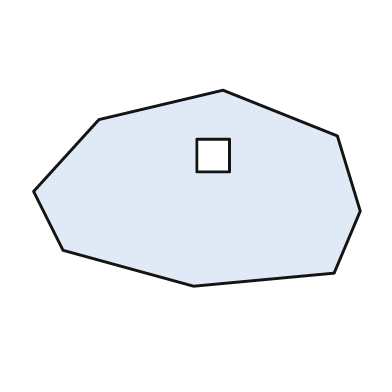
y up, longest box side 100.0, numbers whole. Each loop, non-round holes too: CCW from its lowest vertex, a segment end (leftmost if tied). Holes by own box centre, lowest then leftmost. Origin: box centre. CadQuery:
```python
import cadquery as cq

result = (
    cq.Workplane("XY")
    .moveTo(-1.0, -30.0)
    .lineTo(42.0, -26.0)
    .lineTo(50.0, -7.0)
    .lineTo(43.0, 16.0)
    .lineTo(8.0, 30.0)
    .lineTo(-30.0, 21.0)
    .lineTo(-50.0, -1.0)
    .lineTo(-41.0, -19.0)
    .close()
    .moveTo(0.0, 5.0)
    .lineTo(10.0, 5.0)
    .lineTo(10.0, 15.0)
    .lineTo(0.0, 15.0)
    .close()
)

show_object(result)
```